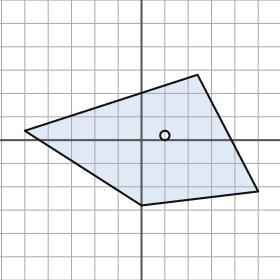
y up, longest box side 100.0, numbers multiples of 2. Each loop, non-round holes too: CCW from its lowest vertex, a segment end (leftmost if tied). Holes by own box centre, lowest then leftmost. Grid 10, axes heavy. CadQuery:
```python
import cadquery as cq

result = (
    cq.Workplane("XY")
    .moveTo(0.0, -28.0)
    .lineTo(50.0, -22.0)
    .lineTo(24.0, 28.0)
    .lineTo(-50.0, 4.0)
    .close()
    .moveTo(10.0, 2.0)
    .circle(2.0)
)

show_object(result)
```